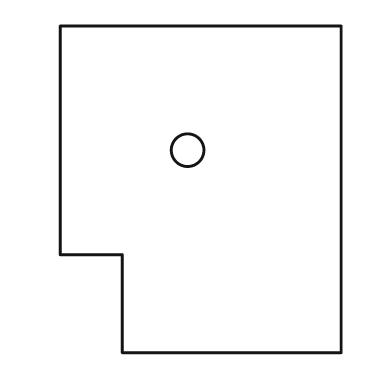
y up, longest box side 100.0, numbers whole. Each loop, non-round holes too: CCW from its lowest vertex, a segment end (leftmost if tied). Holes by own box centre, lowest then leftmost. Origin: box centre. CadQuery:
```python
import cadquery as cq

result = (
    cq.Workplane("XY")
    .moveTo(-24.0, -50.0)
    .lineTo(43.0, -50.0)
    .lineTo(43.0, 50.0)
    .lineTo(-43.0, 50.0)
    .lineTo(-43.0, -20.0)
    .lineTo(-24.0, -20.0)
    .close()
    .moveTo(-4.0, 12.0)
    .circle(5.0)
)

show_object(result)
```